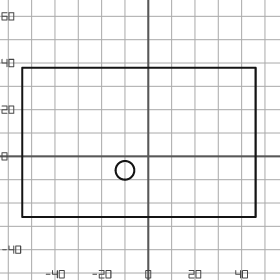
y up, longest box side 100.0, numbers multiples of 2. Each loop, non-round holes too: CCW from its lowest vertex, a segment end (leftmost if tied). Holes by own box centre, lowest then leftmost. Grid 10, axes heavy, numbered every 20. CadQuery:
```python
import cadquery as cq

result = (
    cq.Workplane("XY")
    .moveTo(-54.0, -26.0)
    .lineTo(46.0, -26.0)
    .lineTo(46.0, 38.0)
    .lineTo(-54.0, 38.0)
    .close()
    .moveTo(-10.0, -6.0)
    .circle(4.0)
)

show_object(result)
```